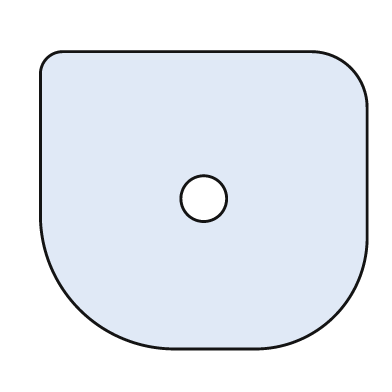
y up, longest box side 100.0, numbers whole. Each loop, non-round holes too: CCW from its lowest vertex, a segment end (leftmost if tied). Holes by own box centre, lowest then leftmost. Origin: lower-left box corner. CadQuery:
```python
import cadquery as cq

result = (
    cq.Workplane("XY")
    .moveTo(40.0, 0.0)
    .lineTo(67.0, 0.0)
    .threePointArc((90.0, 10.0), (100.0, 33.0))
    .lineTo(100.0, 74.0)
    .threePointArc((95.0, 86.0), (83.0, 91.0))
    .lineTo(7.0, 91.0)
    .threePointArc((2.0, 89.0), (0.0, 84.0))
    .lineTo(0.0, 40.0)
    .threePointArc((12.0, 12.0), (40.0, 0.0))
    .close()
    .moveTo(50.0, 46.0)
    .circle(7.0)
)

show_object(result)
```